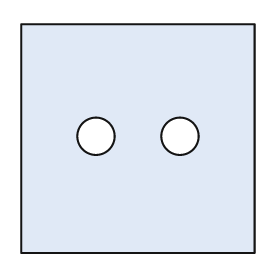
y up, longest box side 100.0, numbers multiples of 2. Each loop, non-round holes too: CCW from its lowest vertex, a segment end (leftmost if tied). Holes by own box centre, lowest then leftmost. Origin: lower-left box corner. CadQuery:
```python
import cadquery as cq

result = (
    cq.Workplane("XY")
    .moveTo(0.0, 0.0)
    .lineTo(100.0, 0.0)
    .lineTo(100.0, 98.0)
    .lineTo(0.0, 98.0)
    .close()
    .moveTo(32.0, 50.0)
    .circle(8.0)
    .moveTo(68.0, 50.0)
    .circle(8.0)
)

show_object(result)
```